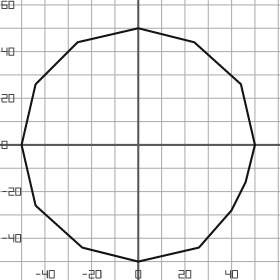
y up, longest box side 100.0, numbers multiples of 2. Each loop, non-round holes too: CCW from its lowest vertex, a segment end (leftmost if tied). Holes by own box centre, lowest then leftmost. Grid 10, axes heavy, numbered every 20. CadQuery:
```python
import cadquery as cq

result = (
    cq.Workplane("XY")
    .moveTo(0.0, -50.0)
    .lineTo(26.0, -44.0)
    .lineTo(40.0, -28.0)
    .lineTo(46.0, -16.0)
    .lineTo(50.0, 0.0)
    .lineTo(44.0, 26.0)
    .lineTo(24.0, 44.0)
    .lineTo(0.0, 50.0)
    .lineTo(-26.0, 44.0)
    .lineTo(-44.0, 26.0)
    .lineTo(-50.0, 0.0)
    .lineTo(-44.0, -26.0)
    .lineTo(-24.0, -44.0)
    .close()
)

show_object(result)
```